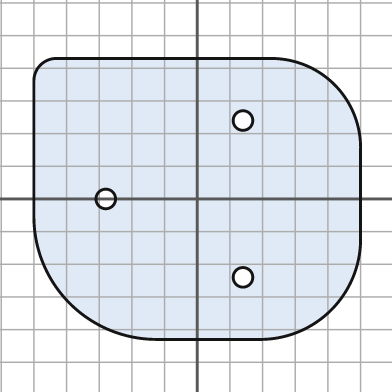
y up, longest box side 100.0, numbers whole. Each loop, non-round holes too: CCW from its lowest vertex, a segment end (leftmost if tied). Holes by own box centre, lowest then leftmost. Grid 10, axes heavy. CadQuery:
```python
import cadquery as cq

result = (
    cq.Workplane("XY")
    .moveTo(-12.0, -43.0)
    .lineTo(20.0, -43.0)
    .threePointArc((41.0, -34.0), (50.0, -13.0))
    .lineTo(50.0, 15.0)
    .threePointArc((42.0, 35.0), (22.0, 43.0))
    .lineTo(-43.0, 43.0)
    .threePointArc((-48.0, 41.0), (-50.0, 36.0))
    .lineTo(-50.0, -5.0)
    .threePointArc((-39.0, -32.0), (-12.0, -43.0))
    .close()
    .moveTo(14.0, -24.0)
    .circle(3.0)
    .moveTo(-28.0, 0.0)
    .circle(3.0)
    .moveTo(14.0, 24.0)
    .circle(3.0)
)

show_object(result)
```